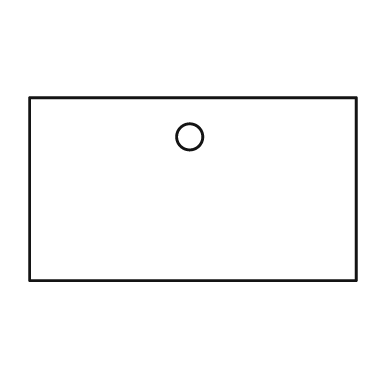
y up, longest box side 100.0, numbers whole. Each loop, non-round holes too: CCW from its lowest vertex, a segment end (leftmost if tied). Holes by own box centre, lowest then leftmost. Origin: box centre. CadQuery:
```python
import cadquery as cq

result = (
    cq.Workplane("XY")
    .moveTo(-50.0, -28.0)
    .lineTo(50.0, -28.0)
    .lineTo(50.0, 28.0)
    .lineTo(-50.0, 28.0)
    .close()
    .moveTo(-1.0, 16.0)
    .circle(4.0)
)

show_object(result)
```